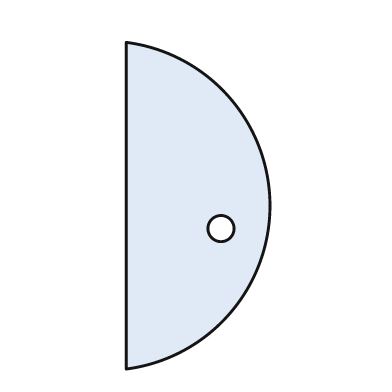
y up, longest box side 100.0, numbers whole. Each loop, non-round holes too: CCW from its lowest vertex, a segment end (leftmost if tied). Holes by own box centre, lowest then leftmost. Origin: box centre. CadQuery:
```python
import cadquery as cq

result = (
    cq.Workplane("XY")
    .moveTo(-22.0, -50.0)
    .threePointArc((22.0, 0.0), (-22.0, 50.0))
    .close()
    .moveTo(7.0, -7.0)
    .circle(4.0)
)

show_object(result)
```